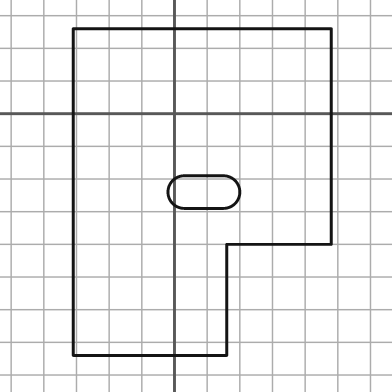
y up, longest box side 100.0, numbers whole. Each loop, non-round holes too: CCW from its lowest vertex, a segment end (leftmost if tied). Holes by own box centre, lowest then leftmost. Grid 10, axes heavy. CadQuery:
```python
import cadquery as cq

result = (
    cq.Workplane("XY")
    .moveTo(-31.0, -74.0)
    .lineTo(16.0, -74.0)
    .lineTo(16.0, -40.0)
    .lineTo(48.0, -40.0)
    .lineTo(48.0, 26.0)
    .lineTo(-31.0, 26.0)
    .close()
    .moveTo(3.0, -29.0)
    .lineTo(15.0, -29.0)
    .threePointArc((20.0, -24.0), (15.0, -19.0))
    .lineTo(3.0, -19.0)
    .threePointArc((-2.0, -24.0), (3.0, -29.0))
    .close()
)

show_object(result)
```